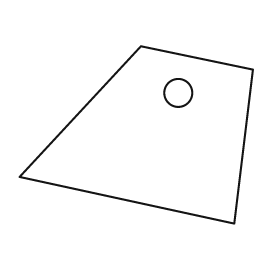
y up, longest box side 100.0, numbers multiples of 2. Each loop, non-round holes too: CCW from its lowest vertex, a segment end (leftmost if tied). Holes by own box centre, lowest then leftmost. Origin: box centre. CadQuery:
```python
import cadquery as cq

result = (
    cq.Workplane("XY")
    .moveTo(42.0, -38.0)
    .lineTo(50.0, 28.0)
    .lineTo(2.0, 38.0)
    .lineTo(-50.0, -18.0)
    .close()
    .moveTo(18.0, 18.0)
    .circle(6.0)
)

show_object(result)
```